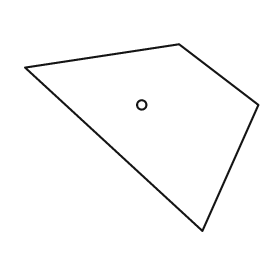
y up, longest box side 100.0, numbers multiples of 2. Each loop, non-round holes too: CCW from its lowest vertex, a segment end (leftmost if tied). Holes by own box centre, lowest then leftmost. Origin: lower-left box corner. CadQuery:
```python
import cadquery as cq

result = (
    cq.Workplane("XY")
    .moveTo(76.0, 0.0)
    .lineTo(100.0, 54.0)
    .lineTo(66.0, 80.0)
    .lineTo(0.0, 70.0)
    .close()
    .moveTo(50.0, 54.0)
    .circle(2.0)
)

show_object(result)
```